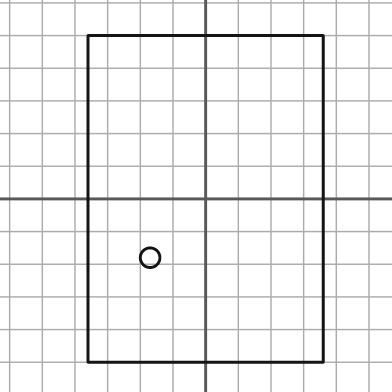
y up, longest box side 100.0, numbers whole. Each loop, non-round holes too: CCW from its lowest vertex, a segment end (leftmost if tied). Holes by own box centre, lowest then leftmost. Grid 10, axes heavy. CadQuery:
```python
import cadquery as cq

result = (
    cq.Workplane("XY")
    .moveTo(-36.0, -50.0)
    .lineTo(36.0, -50.0)
    .lineTo(36.0, 50.0)
    .lineTo(-36.0, 50.0)
    .close()
    .moveTo(-17.0, -18.0)
    .circle(3.0)
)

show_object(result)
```